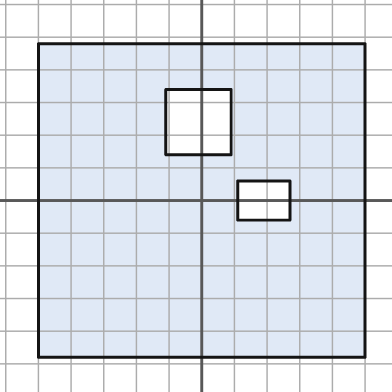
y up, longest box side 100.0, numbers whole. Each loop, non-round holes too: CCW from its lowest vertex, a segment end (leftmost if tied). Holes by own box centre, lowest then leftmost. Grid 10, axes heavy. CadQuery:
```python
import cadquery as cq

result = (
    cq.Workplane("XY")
    .moveTo(-50.0, -48.0)
    .lineTo(50.0, -48.0)
    .lineTo(50.0, 48.0)
    .lineTo(-50.0, 48.0)
    .close()
    .moveTo(11.0, -6.0)
    .lineTo(27.0, -6.0)
    .lineTo(27.0, 6.0)
    .lineTo(11.0, 6.0)
    .close()
    .moveTo(-11.0, 14.0)
    .lineTo(9.0, 14.0)
    .lineTo(9.0, 34.0)
    .lineTo(-11.0, 34.0)
    .close()
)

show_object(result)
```